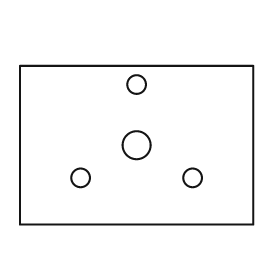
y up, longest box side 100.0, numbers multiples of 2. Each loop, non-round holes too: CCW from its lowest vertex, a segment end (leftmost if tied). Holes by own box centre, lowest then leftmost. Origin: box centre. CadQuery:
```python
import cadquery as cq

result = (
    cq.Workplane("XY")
    .moveTo(-50.0, -34.0)
    .lineTo(50.0, -34.0)
    .lineTo(50.0, 34.0)
    .lineTo(-50.0, 34.0)
    .close()
    .moveTo(-24.0, -14.0)
    .circle(4.0)
    .moveTo(24.0, -14.0)
    .circle(4.0)
    .moveTo(0.0, 0.0)
    .circle(6.0)
    .moveTo(0.0, 26.0)
    .circle(4.0)
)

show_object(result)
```